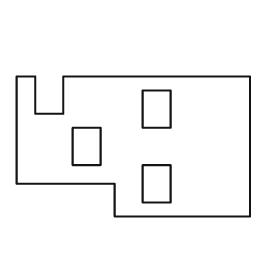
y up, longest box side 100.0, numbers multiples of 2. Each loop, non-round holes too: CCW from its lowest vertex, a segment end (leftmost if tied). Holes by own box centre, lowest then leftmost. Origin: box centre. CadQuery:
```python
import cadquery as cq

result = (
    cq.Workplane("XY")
    .moveTo(-8.0, -30.0)
    .lineTo(50.0, -30.0)
    .lineTo(50.0, 30.0)
    .lineTo(-30.0, 30.0)
    .lineTo(-30.0, 14.0)
    .lineTo(-42.0, 14.0)
    .lineTo(-42.0, 30.0)
    .lineTo(-50.0, 30.0)
    .lineTo(-50.0, -16.0)
    .lineTo(-8.0, -16.0)
    .close()
    .moveTo(4.0, -24.0)
    .lineTo(16.0, -24.0)
    .lineTo(16.0, -8.0)
    .lineTo(4.0, -8.0)
    .close()
    .moveTo(-26.0, -8.0)
    .lineTo(-14.0, -8.0)
    .lineTo(-14.0, 8.0)
    .lineTo(-26.0, 8.0)
    .close()
    .moveTo(4.0, 8.0)
    .lineTo(16.0, 8.0)
    .lineTo(16.0, 24.0)
    .lineTo(4.0, 24.0)
    .close()
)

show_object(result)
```